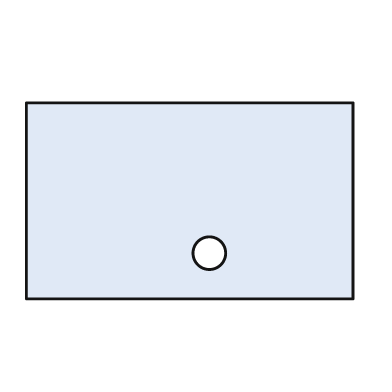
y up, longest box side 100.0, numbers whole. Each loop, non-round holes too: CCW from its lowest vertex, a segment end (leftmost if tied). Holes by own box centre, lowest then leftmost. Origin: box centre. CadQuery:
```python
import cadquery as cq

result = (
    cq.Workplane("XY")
    .moveTo(-50.0, -30.0)
    .lineTo(50.0, -30.0)
    .lineTo(50.0, 30.0)
    .lineTo(-50.0, 30.0)
    .close()
    .moveTo(6.0, -16.0)
    .circle(5.0)
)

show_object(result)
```